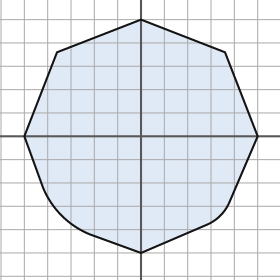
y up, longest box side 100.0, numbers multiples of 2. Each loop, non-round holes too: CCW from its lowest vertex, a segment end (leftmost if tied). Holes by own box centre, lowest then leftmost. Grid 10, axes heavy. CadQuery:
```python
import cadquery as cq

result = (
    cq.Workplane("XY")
    .moveTo(0.0, -50.0)
    .lineTo(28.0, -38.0)
    .threePointArc((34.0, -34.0), (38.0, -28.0))
    .lineTo(50.0, 0.0)
    .lineTo(36.0, 36.0)
    .lineTo(0.0, 50.0)
    .lineTo(-36.0, 36.0)
    .lineTo(-50.0, 0.0)
    .lineTo(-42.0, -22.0)
    .threePointArc((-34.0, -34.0), (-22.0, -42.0))
    .close()
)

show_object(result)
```